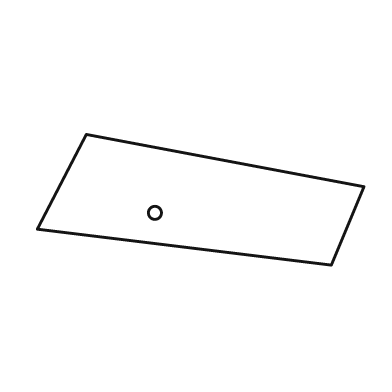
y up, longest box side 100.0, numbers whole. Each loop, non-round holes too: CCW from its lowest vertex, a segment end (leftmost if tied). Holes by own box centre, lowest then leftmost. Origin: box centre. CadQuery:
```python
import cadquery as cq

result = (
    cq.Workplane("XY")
    .moveTo(40.0, -20.0)
    .lineTo(50.0, 4.0)
    .lineTo(-35.0, 20.0)
    .lineTo(-50.0, -9.0)
    .close()
    .moveTo(-14.0, -4.0)
    .circle(2.0)
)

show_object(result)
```